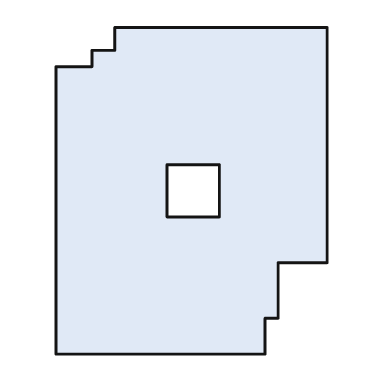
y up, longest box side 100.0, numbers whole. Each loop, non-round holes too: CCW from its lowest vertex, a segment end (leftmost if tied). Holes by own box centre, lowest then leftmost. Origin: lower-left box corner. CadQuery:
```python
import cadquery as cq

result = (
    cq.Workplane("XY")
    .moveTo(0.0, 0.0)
    .lineTo(64.0, 0.0)
    .lineTo(64.0, 11.0)
    .lineTo(68.0, 11.0)
    .lineTo(68.0, 28.0)
    .lineTo(83.0, 28.0)
    .lineTo(83.0, 100.0)
    .lineTo(18.0, 100.0)
    .lineTo(18.0, 93.0)
    .lineTo(11.0, 93.0)
    .lineTo(11.0, 88.0)
    .lineTo(0.0, 88.0)
    .close()
    .moveTo(34.0, 42.0)
    .lineTo(50.0, 42.0)
    .lineTo(50.0, 58.0)
    .lineTo(34.0, 58.0)
    .close()
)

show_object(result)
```